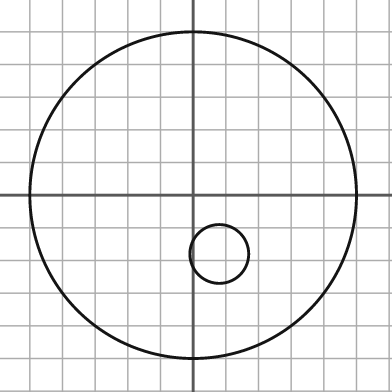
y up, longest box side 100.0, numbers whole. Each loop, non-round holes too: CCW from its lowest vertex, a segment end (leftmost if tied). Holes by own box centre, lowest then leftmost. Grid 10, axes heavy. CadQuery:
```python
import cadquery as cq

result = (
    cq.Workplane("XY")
    .moveTo(0.0, 0.0)
    .circle(50.0)
    .moveTo(8.0, -18.0)
    .circle(9.0)
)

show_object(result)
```